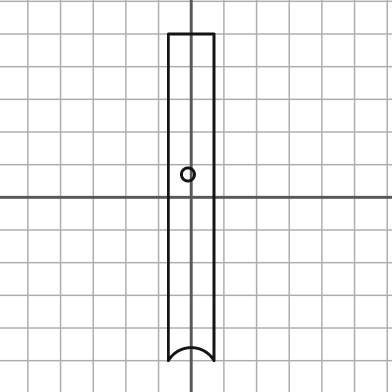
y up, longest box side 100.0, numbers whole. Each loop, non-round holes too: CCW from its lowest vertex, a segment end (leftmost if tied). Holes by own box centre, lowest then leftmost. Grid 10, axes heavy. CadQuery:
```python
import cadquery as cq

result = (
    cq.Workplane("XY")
    .moveTo(-7.0, -50.0)
    .threePointArc((0.0, -46.0), (7.0, -50.0))
    .lineTo(7.0, 50.0)
    .lineTo(-7.0, 50.0)
    .close()
    .moveTo(-1.0, 7.0)
    .circle(2.0)
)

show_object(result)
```